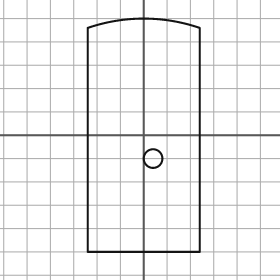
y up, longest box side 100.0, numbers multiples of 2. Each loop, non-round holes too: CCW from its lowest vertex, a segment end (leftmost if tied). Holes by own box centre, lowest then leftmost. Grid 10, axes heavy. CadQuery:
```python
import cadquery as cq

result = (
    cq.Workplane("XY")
    .moveTo(-24.0, -50.0)
    .lineTo(24.0, -50.0)
    .lineTo(24.0, 46.0)
    .threePointArc((0.0, 50.0), (-24.0, 46.0))
    .close()
    .moveTo(4.0, -10.0)
    .circle(4.0)
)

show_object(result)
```